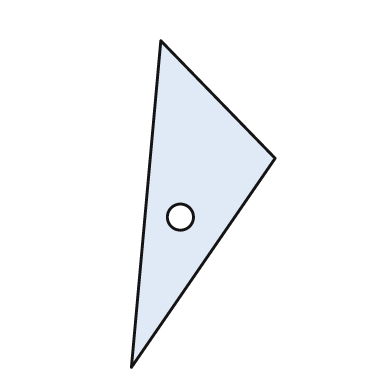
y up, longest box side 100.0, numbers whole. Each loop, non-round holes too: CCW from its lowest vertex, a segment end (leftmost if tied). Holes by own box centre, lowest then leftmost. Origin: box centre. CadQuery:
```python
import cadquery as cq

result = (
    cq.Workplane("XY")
    .moveTo(-22.0, -50.0)
    .lineTo(22.0, 14.0)
    .lineTo(-13.0, 50.0)
    .close()
    .moveTo(-7.0, -4.0)
    .circle(4.0)
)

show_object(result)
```